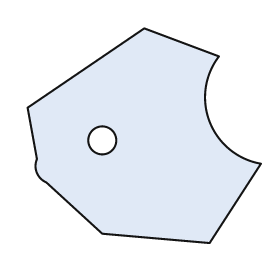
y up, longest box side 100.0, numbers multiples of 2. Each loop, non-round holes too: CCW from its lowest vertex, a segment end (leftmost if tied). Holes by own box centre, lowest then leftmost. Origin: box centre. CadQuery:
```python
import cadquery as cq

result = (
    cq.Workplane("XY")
    .moveTo(28.0, -46.0)
    .lineTo(50.0, -12.0)
    .threePointArc((28.0, 6.0), (32.0, 34.0))
    .lineTo(0.0, 46.0)
    .lineTo(-50.0, 12.0)
    .lineTo(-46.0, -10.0)
    .threePointArc((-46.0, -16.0), (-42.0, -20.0))
    .lineTo(-18.0, -42.0)
    .close()
    .moveTo(-18.0, -2.0)
    .circle(6.0)
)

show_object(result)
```